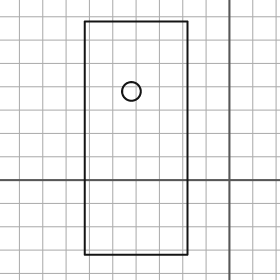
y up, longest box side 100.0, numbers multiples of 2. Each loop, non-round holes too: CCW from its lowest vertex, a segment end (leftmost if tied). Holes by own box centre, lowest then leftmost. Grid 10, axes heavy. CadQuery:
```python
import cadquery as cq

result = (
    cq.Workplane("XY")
    .moveTo(-62.0, -32.0)
    .lineTo(-18.0, -32.0)
    .lineTo(-18.0, 68.0)
    .lineTo(-62.0, 68.0)
    .close()
    .moveTo(-42.0, 38.0)
    .circle(4.0)
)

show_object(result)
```